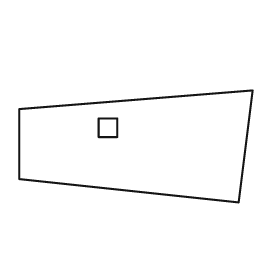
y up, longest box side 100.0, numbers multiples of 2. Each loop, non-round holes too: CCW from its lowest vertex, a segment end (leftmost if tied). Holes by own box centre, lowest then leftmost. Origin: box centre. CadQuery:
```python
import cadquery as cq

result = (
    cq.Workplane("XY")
    .moveTo(44.0, -24.0)
    .lineTo(50.0, 24.0)
    .lineTo(-50.0, 16.0)
    .lineTo(-50.0, -14.0)
    .close()
    .moveTo(-16.0, 4.0)
    .lineTo(-8.0, 4.0)
    .lineTo(-8.0, 12.0)
    .lineTo(-16.0, 12.0)
    .close()
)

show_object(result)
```